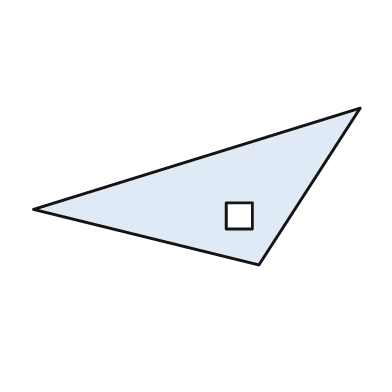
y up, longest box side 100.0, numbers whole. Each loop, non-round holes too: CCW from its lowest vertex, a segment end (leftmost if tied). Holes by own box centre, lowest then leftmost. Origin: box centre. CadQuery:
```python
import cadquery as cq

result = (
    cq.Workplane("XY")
    .moveTo(19.0, -24.0)
    .lineTo(50.0, 24.0)
    .lineTo(-50.0, -7.0)
    .close()
    .moveTo(9.0, -13.0)
    .lineTo(17.0, -13.0)
    .lineTo(17.0, -5.0)
    .lineTo(9.0, -5.0)
    .close()
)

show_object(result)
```